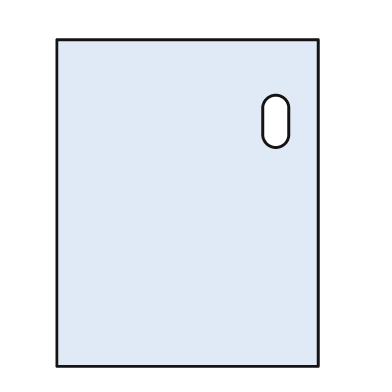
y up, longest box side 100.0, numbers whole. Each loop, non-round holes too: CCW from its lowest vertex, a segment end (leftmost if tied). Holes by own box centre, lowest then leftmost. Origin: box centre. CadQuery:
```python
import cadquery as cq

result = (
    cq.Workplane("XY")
    .moveTo(-40.0, -50.0)
    .lineTo(40.0, -50.0)
    .lineTo(40.0, 50.0)
    .lineTo(-40.0, 50.0)
    .close()
    .moveTo(23.0, 21.0)
    .threePointArc((27.0, 17.0), (31.0, 21.0))
    .lineTo(31.0, 29.0)
    .threePointArc((27.0, 33.0), (23.0, 29.0))
    .close()
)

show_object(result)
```